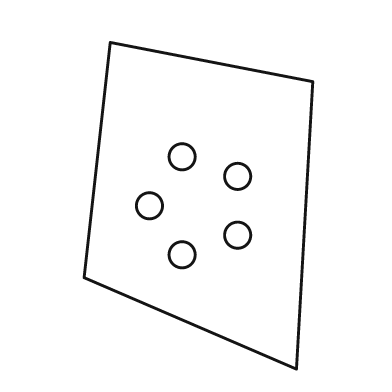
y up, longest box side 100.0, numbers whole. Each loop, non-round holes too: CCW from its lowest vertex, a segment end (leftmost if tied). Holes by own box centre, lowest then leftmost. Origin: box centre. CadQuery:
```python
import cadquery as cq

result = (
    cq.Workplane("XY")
    .moveTo(30.0, -50.0)
    .lineTo(35.0, 38.0)
    .lineTo(-27.0, 50.0)
    .lineTo(-35.0, -22.0)
    .close()
    .moveTo(-5.0, -15.0)
    .circle(4.0)
    .moveTo(12.0, -9.0)
    .circle(4.0)
    .moveTo(-15.0, 0.0)
    .circle(4.0)
    .moveTo(12.0, 9.0)
    .circle(4.0)
    .moveTo(-5.0, 15.0)
    .circle(4.0)
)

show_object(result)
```